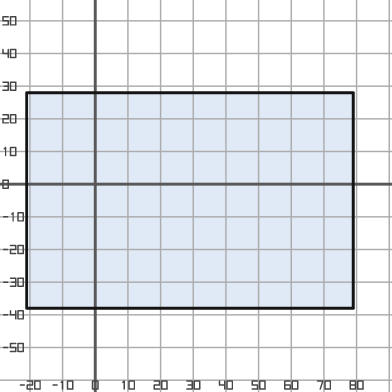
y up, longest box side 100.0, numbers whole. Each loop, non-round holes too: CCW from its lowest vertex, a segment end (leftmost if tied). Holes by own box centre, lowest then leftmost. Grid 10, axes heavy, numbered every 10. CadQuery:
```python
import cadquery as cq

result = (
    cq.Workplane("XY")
    .moveTo(-21.0, -38.0)
    .lineTo(79.0, -38.0)
    .lineTo(79.0, 28.0)
    .lineTo(-21.0, 28.0)
    .close()
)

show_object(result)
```